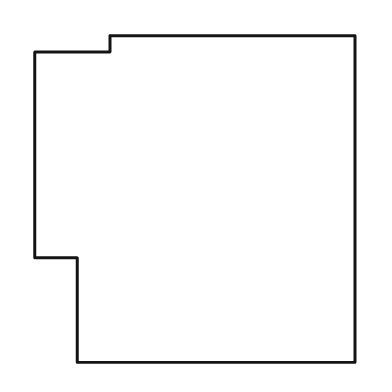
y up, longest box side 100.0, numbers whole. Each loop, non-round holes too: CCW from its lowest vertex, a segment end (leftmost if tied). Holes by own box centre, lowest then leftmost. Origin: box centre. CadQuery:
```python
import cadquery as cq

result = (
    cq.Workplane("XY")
    .moveTo(-36.0, -50.0)
    .lineTo(49.0, -50.0)
    .lineTo(49.0, 50.0)
    .lineTo(-26.0, 50.0)
    .lineTo(-26.0, 45.0)
    .lineTo(-49.0, 45.0)
    .lineTo(-49.0, -18.0)
    .lineTo(-36.0, -18.0)
    .close()
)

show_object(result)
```